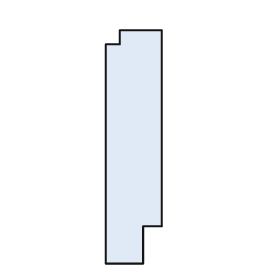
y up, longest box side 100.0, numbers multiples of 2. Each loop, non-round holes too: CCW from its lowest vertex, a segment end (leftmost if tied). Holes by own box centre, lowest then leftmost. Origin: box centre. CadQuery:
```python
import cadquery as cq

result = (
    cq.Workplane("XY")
    .moveTo(-12.0, -50.0)
    .lineTo(4.0, -50.0)
    .lineTo(4.0, -34.0)
    .lineTo(12.0, -34.0)
    .lineTo(12.0, 50.0)
    .lineTo(-6.0, 50.0)
    .lineTo(-6.0, 44.0)
    .lineTo(-12.0, 44.0)
    .close()
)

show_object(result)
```